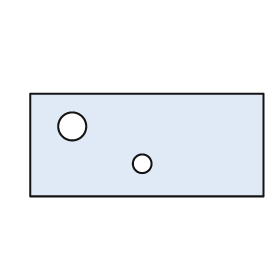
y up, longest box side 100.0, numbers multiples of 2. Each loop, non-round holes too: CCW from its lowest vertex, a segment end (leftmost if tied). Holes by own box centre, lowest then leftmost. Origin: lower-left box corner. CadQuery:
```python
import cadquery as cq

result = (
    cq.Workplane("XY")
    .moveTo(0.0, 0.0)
    .lineTo(100.0, 0.0)
    .lineTo(100.0, 44.0)
    .lineTo(0.0, 44.0)
    .close()
    .moveTo(48.0, 14.0)
    .circle(4.0)
    .moveTo(18.0, 30.0)
    .circle(6.0)
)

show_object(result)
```